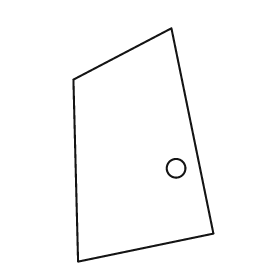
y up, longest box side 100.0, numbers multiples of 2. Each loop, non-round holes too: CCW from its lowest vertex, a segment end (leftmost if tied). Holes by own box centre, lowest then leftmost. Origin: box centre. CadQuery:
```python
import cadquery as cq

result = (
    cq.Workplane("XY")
    .moveTo(-28.0, -50.0)
    .lineTo(30.0, -38.0)
    .lineTo(12.0, 50.0)
    .lineTo(-30.0, 28.0)
    .close()
    .moveTo(14.0, -10.0)
    .circle(4.0)
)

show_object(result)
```